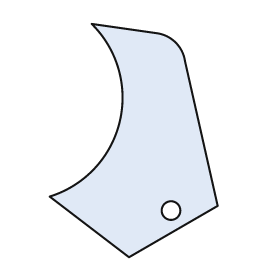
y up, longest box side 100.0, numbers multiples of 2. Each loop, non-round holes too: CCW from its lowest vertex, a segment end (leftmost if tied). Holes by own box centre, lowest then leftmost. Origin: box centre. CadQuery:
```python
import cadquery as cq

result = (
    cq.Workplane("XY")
    .moveTo(-2.0, -50.0)
    .lineTo(36.0, -28.0)
    .lineTo(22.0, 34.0)
    .threePointArc((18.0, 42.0), (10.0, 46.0))
    .lineTo(-18.0, 50.0)
    .threePointArc((-6.0, 8.0), (-36.0, -24.0))
    .close()
    .moveTo(16.0, -30.0)
    .circle(4.0)
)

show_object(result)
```